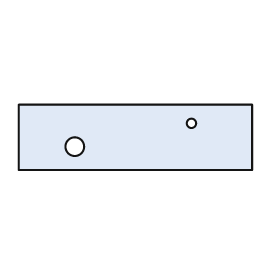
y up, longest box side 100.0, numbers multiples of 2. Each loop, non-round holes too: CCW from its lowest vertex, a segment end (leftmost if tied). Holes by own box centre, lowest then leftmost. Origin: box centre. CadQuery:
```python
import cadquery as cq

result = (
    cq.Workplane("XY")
    .moveTo(-50.0, -14.0)
    .lineTo(50.0, -14.0)
    .lineTo(50.0, 14.0)
    .lineTo(-50.0, 14.0)
    .close()
    .moveTo(-26.0, -4.0)
    .circle(4.0)
    .moveTo(24.0, 6.0)
    .circle(2.0)
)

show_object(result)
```